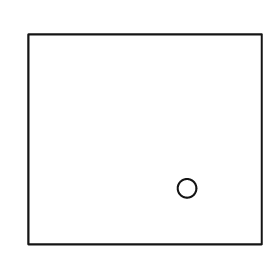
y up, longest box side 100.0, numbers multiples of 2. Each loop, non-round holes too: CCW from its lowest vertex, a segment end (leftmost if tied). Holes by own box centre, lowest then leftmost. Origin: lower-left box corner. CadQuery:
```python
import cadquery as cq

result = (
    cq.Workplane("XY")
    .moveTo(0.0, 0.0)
    .lineTo(100.0, 0.0)
    .lineTo(100.0, 90.0)
    .lineTo(0.0, 90.0)
    .close()
    .moveTo(68.0, 24.0)
    .circle(4.0)
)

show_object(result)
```